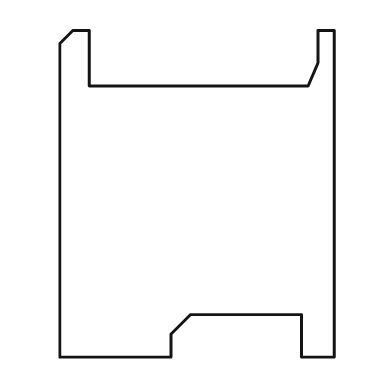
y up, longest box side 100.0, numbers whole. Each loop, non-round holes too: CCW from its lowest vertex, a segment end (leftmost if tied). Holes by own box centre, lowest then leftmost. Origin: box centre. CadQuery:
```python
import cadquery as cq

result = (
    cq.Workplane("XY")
    .moveTo(-42.0, -50.0)
    .lineTo(-8.0, -50.0)
    .lineTo(-8.0, -43.0)
    .lineTo(-2.0, -37.0)
    .lineTo(32.0, -37.0)
    .lineTo(32.0, -50.0)
    .lineTo(42.0, -50.0)
    .lineTo(42.0, 50.0)
    .lineTo(37.0, 50.0)
    .lineTo(37.0, 40.0)
    .lineTo(34.0, 33.0)
    .lineTo(-33.0, 33.0)
    .lineTo(-33.0, 50.0)
    .lineTo(-38.0, 50.0)
    .lineTo(-42.0, 46.0)
    .close()
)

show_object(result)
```